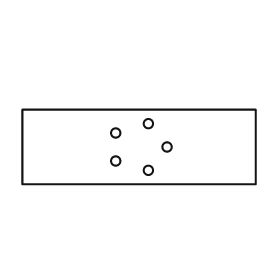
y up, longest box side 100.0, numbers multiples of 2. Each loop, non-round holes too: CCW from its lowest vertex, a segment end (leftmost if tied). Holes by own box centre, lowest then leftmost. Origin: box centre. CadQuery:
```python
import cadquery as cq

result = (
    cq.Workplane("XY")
    .moveTo(-50.0, -16.0)
    .lineTo(50.0, -16.0)
    .lineTo(50.0, 16.0)
    .lineTo(-50.0, 16.0)
    .close()
    .moveTo(4.0, -10.0)
    .circle(2.0)
    .moveTo(-10.0, -6.0)
    .circle(2.0)
    .moveTo(12.0, 0.0)
    .circle(2.0)
    .moveTo(-10.0, 6.0)
    .circle(2.0)
    .moveTo(4.0, 10.0)
    .circle(2.0)
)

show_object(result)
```